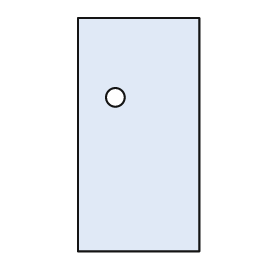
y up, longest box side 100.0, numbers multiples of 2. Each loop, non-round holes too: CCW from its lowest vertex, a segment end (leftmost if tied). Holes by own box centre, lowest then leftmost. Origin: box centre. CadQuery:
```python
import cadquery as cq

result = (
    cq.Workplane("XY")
    .moveTo(-26.0, -50.0)
    .lineTo(26.0, -50.0)
    .lineTo(26.0, 50.0)
    .lineTo(-26.0, 50.0)
    .close()
    .moveTo(-10.0, 16.0)
    .circle(4.0)
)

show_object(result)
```